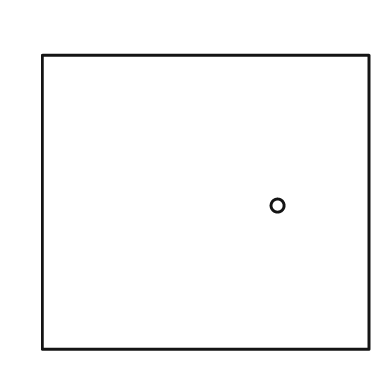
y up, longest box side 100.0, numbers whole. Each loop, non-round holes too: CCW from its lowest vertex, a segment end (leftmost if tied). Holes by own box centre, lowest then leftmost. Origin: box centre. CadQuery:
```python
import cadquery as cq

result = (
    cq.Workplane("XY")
    .moveTo(-50.0, -45.0)
    .lineTo(50.0, -45.0)
    .lineTo(50.0, 45.0)
    .lineTo(-50.0, 45.0)
    .close()
    .moveTo(22.0, -1.0)
    .circle(2.0)
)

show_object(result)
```